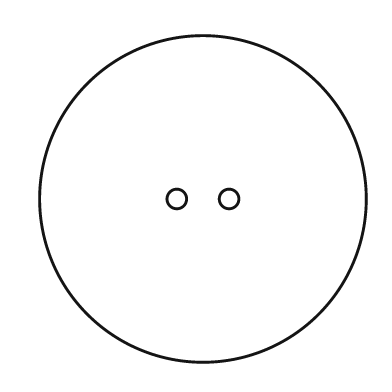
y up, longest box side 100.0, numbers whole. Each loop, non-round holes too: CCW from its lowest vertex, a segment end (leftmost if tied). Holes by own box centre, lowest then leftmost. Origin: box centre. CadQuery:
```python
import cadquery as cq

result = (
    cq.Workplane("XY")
    .moveTo(0.0, 0.0)
    .circle(50.0)
    .moveTo(-8.0, 0.0)
    .circle(3.0)
    .moveTo(8.0, 0.0)
    .circle(3.0)
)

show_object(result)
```